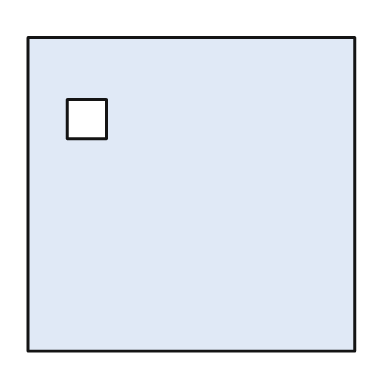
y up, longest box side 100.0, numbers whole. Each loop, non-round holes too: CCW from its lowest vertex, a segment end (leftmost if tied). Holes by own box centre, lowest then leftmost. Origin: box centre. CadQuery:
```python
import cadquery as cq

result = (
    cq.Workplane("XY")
    .moveTo(-50.0, -48.0)
    .lineTo(50.0, -48.0)
    .lineTo(50.0, 48.0)
    .lineTo(-50.0, 48.0)
    .close()
    .moveTo(-38.0, 17.0)
    .lineTo(-26.0, 17.0)
    .lineTo(-26.0, 29.0)
    .lineTo(-38.0, 29.0)
    .close()
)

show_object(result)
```